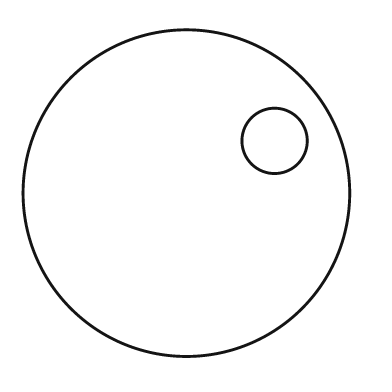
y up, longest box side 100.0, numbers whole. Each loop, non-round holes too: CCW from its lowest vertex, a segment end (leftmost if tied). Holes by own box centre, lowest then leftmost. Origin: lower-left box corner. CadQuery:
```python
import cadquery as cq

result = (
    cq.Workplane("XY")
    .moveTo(50.0, 50.0)
    .circle(50.0)
    .moveTo(77.0, 66.0)
    .circle(10.0)
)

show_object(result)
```